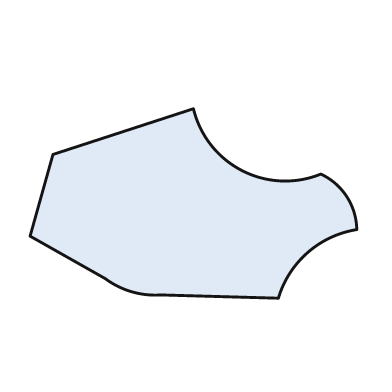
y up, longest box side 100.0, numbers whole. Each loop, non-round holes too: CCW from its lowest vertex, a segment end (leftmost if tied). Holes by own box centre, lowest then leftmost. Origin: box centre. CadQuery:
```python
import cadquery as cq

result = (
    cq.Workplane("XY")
    .moveTo(26.0, -29.0)
    .threePointArc((35.0, -15.0), (50.0, -8.0))
    .threePointArc((47.0, 2.0), (39.0, 9.0))
    .threePointArc((15.0, 10.0), (0.0, 29.0))
    .lineTo(-43.0, 15.0)
    .lineTo(-50.0, -10.0)
    .lineTo(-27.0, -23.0)
    .threePointArc((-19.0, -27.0), (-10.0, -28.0))
    .close()
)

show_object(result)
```